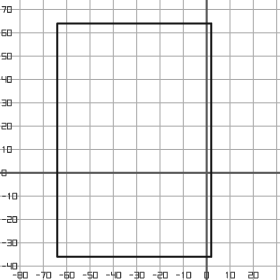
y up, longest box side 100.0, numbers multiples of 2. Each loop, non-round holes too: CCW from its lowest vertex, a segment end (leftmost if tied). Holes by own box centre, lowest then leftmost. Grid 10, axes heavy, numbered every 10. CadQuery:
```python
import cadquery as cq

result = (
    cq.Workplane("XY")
    .moveTo(-64.0, -36.0)
    .lineTo(2.0, -36.0)
    .lineTo(2.0, 64.0)
    .lineTo(-64.0, 64.0)
    .close()
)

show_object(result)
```